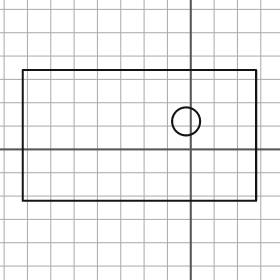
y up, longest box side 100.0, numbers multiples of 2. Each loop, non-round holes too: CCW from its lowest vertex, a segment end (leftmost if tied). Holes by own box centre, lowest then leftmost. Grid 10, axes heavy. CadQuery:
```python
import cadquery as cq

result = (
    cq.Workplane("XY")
    .moveTo(-72.0, -22.0)
    .lineTo(28.0, -22.0)
    .lineTo(28.0, 34.0)
    .lineTo(-72.0, 34.0)
    .close()
    .moveTo(-2.0, 12.0)
    .circle(6.0)
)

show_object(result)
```